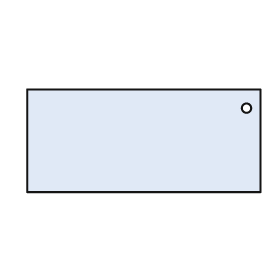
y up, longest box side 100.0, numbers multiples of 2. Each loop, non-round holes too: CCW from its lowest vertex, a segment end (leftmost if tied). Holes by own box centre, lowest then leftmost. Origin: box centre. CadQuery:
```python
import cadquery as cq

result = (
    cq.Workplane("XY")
    .moveTo(-50.0, -22.0)
    .lineTo(50.0, -22.0)
    .lineTo(50.0, 22.0)
    .lineTo(-50.0, 22.0)
    .close()
    .moveTo(44.0, 14.0)
    .circle(2.0)
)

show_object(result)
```